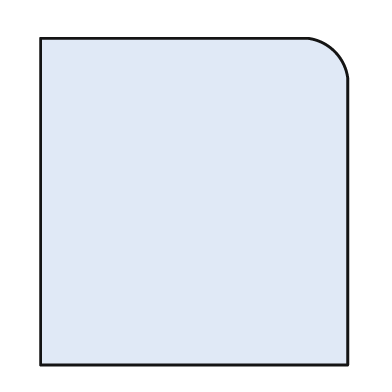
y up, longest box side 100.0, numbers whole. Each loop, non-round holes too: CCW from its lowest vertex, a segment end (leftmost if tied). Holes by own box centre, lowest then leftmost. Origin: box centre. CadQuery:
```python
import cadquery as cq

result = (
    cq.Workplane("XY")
    .moveTo(-47.0, -50.0)
    .lineTo(47.0, -50.0)
    .lineTo(47.0, 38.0)
    .threePointArc((43.0, 46.0), (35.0, 50.0))
    .lineTo(-47.0, 50.0)
    .close()
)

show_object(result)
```